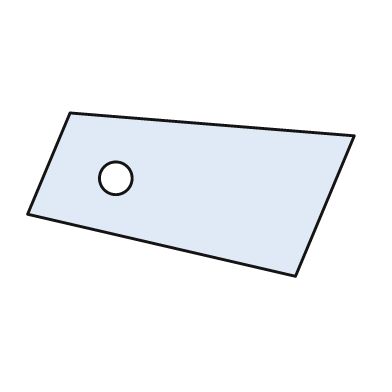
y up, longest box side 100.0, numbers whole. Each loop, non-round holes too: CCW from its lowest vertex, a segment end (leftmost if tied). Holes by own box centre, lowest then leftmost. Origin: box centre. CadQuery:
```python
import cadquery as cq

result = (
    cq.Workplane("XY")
    .moveTo(32.0, -25.0)
    .lineTo(50.0, 18.0)
    .lineTo(-37.0, 25.0)
    .lineTo(-50.0, -6.0)
    .close()
    .moveTo(-23.0, 5.0)
    .circle(5.0)
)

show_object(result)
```